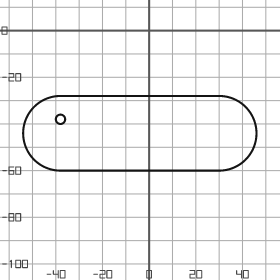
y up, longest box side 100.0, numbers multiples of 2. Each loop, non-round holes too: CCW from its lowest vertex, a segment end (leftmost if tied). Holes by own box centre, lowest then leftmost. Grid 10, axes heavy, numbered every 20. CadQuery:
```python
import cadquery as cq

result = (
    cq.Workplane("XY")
    .moveTo(-38.0, -60.0)
    .lineTo(30.0, -60.0)
    .threePointArc((46.0, -44.0), (30.0, -28.0))
    .lineTo(-38.0, -28.0)
    .threePointArc((-54.0, -44.0), (-38.0, -60.0))
    .close()
    .moveTo(-38.0, -38.0)
    .circle(2.0)
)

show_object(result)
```